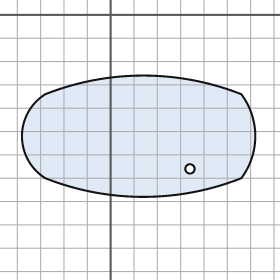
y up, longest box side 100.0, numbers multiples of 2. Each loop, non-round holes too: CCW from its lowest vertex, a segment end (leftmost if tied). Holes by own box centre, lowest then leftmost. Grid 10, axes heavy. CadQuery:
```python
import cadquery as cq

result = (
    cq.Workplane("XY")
    .moveTo(-28.0, -70.0)
    .threePointArc((14.0, -78.0), (56.0, -70.0))
    .threePointArc((62.0, -52.0), (56.0, -34.0))
    .threePointArc((14.0, -26.0), (-28.0, -34.0))
    .threePointArc((-38.0, -52.0), (-28.0, -70.0))
    .close()
    .moveTo(34.0, -66.0)
    .circle(2.0)
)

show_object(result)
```